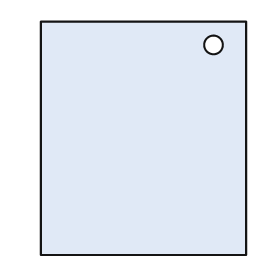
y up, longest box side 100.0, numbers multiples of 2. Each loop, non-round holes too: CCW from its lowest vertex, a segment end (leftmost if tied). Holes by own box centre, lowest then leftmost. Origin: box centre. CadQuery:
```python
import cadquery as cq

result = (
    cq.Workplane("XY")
    .moveTo(-44.0, -50.0)
    .lineTo(44.0, -50.0)
    .lineTo(44.0, 50.0)
    .lineTo(-44.0, 50.0)
    .close()
    .moveTo(30.0, 40.0)
    .circle(4.0)
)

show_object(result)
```